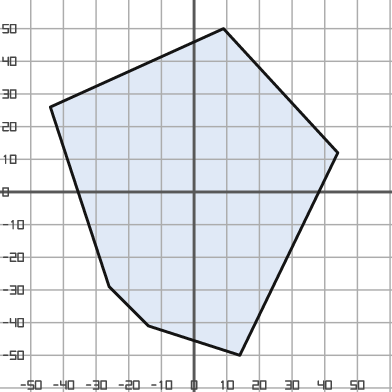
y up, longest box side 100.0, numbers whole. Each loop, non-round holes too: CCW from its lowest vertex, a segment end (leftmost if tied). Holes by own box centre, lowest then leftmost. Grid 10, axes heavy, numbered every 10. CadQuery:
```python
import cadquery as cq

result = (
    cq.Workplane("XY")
    .moveTo(14.0, -50.0)
    .lineTo(44.0, 12.0)
    .lineTo(9.0, 50.0)
    .lineTo(-44.0, 26.0)
    .lineTo(-26.0, -29.0)
    .lineTo(-14.0, -41.0)
    .close()
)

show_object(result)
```